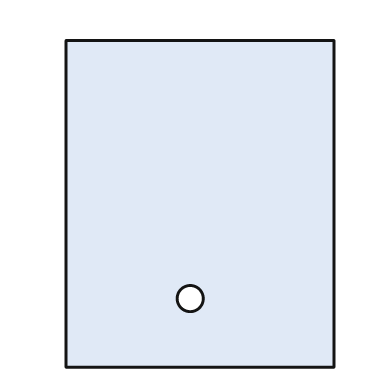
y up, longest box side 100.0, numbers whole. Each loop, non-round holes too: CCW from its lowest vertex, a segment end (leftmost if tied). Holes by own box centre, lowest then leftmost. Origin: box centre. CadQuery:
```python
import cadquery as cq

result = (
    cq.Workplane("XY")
    .moveTo(-41.0, -50.0)
    .lineTo(41.0, -50.0)
    .lineTo(41.0, 50.0)
    .lineTo(-41.0, 50.0)
    .close()
    .moveTo(-3.0, -29.0)
    .circle(4.0)
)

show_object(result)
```